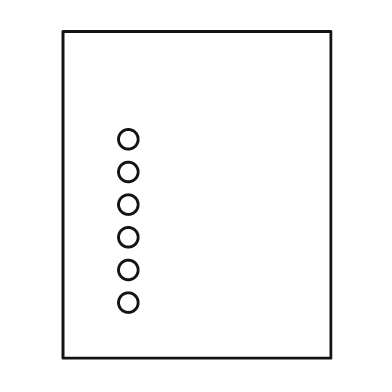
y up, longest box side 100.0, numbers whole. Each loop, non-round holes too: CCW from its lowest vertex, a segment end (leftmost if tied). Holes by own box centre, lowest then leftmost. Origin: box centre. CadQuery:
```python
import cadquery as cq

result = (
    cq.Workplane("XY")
    .moveTo(-41.0, -50.0)
    .lineTo(41.0, -50.0)
    .lineTo(41.0, 50.0)
    .lineTo(-41.0, 50.0)
    .close()
    .moveTo(-21.0, -33.0)
    .circle(3.0)
    .moveTo(-21.0, -23.0)
    .circle(3.0)
    .moveTo(-21.0, -13.0)
    .circle(3.0)
    .moveTo(-21.0, -3.0)
    .circle(3.0)
    .moveTo(-21.0, 7.0)
    .circle(3.0)
    .moveTo(-21.0, 17.0)
    .circle(3.0)
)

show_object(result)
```